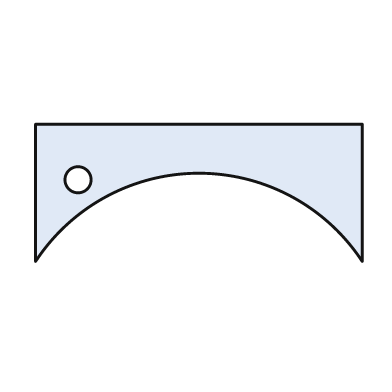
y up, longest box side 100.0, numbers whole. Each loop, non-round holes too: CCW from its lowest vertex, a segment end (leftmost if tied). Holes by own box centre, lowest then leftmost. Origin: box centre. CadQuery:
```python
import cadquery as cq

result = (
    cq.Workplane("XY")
    .moveTo(-50.0, -21.0)
    .threePointArc((0.0, 6.0), (50.0, -21.0))
    .lineTo(50.0, 21.0)
    .lineTo(-50.0, 21.0)
    .close()
    .moveTo(-37.0, 4.0)
    .circle(4.0)
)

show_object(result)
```